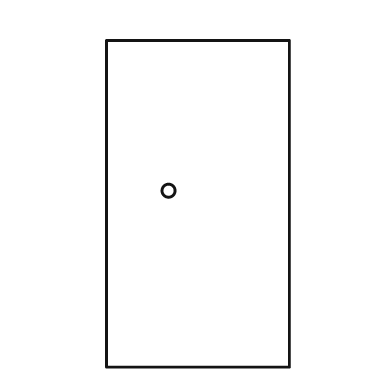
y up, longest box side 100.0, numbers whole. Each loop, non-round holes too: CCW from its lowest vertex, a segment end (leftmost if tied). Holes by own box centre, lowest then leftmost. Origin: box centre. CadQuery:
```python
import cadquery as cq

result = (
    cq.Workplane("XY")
    .moveTo(-28.0, -50.0)
    .lineTo(28.0, -50.0)
    .lineTo(28.0, 50.0)
    .lineTo(-28.0, 50.0)
    .close()
    .moveTo(-9.0, 4.0)
    .circle(2.0)
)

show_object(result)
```